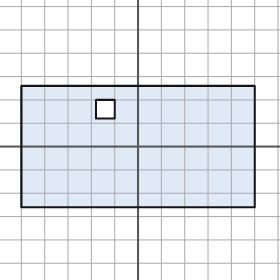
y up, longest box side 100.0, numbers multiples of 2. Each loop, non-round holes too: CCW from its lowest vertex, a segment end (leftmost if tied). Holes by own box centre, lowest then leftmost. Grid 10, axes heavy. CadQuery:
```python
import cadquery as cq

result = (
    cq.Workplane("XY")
    .moveTo(-50.0, -26.0)
    .lineTo(50.0, -26.0)
    .lineTo(50.0, 26.0)
    .lineTo(-50.0, 26.0)
    .close()
    .moveTo(-18.0, 12.0)
    .lineTo(-10.0, 12.0)
    .lineTo(-10.0, 20.0)
    .lineTo(-18.0, 20.0)
    .close()
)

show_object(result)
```